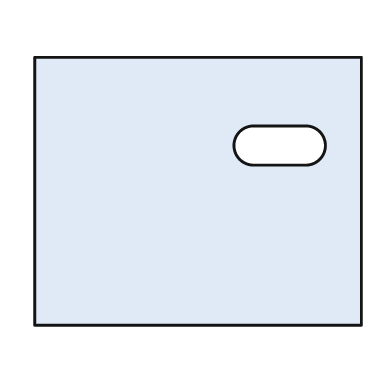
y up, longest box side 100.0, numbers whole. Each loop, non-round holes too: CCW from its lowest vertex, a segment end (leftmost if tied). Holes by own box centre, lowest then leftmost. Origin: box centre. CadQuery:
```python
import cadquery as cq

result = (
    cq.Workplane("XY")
    .moveTo(-50.0, -41.0)
    .lineTo(50.0, -41.0)
    .lineTo(50.0, 41.0)
    .lineTo(-50.0, 41.0)
    .close()
    .moveTo(17.0, 8.0)
    .lineTo(33.0, 8.0)
    .threePointArc((39.0, 14.0), (33.0, 20.0))
    .lineTo(17.0, 20.0)
    .threePointArc((11.0, 14.0), (17.0, 8.0))
    .close()
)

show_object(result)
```